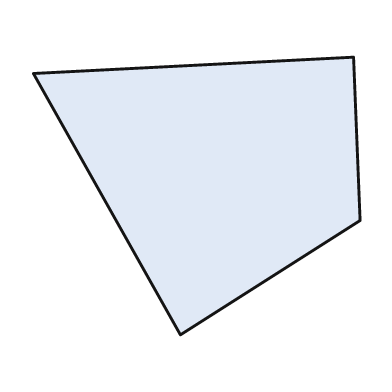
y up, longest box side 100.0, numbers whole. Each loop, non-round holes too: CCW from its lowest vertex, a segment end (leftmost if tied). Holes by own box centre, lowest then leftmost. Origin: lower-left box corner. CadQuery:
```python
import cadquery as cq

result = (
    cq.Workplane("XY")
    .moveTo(45.0, 0.0)
    .lineTo(100.0, 35.0)
    .lineTo(98.0, 85.0)
    .lineTo(0.0, 80.0)
    .close()
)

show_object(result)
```